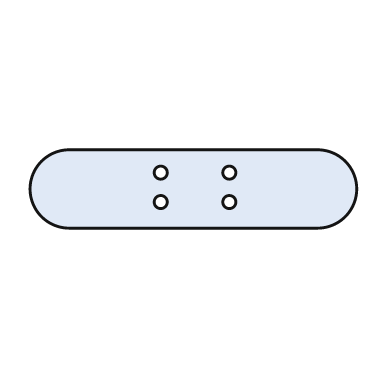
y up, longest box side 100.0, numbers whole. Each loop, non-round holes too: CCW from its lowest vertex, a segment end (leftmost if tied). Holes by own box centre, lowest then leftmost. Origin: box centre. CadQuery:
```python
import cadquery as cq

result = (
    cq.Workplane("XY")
    .moveTo(-38.0, -12.0)
    .lineTo(38.0, -12.0)
    .threePointArc((50.0, 0.0), (38.0, 12.0))
    .lineTo(-38.0, 12.0)
    .threePointArc((-50.0, 0.0), (-38.0, -12.0))
    .close()
    .moveTo(-10.0, -4.0)
    .circle(2.0)
    .moveTo(11.0, -4.0)
    .circle(2.0)
    .moveTo(-10.0, 5.0)
    .circle(2.0)
    .moveTo(11.0, 5.0)
    .circle(2.0)
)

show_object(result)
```